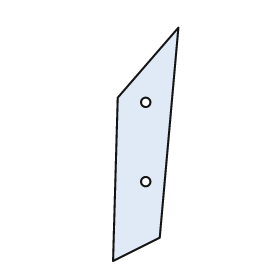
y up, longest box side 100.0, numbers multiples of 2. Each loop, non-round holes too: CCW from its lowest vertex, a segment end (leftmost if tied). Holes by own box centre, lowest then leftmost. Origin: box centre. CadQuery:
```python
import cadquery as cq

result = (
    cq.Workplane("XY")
    .moveTo(-14.0, -50.0)
    .lineTo(6.0, -40.0)
    .lineTo(14.0, 50.0)
    .lineTo(-12.0, 20.0)
    .close()
    .moveTo(0.0, -16.0)
    .circle(2.0)
    .moveTo(0.0, 18.0)
    .circle(2.0)
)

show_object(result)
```